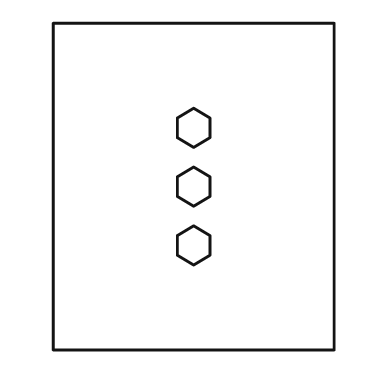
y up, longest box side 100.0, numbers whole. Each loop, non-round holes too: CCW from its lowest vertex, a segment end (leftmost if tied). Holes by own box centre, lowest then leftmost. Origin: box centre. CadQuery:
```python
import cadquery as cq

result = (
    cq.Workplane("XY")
    .moveTo(-43.0, -50.0)
    .lineTo(43.0, -50.0)
    .lineTo(43.0, 50.0)
    .lineTo(-43.0, 50.0)
    .close()
    .moveTo(0.0, -24.0)
    .lineTo(5.0, -21.0)
    .lineTo(5.0, -15.0)
    .lineTo(0.0, -12.0)
    .lineTo(-5.0, -15.0)
    .lineTo(-5.0, -21.0)
    .close()
    .moveTo(0.0, -6.0)
    .lineTo(5.0, -3.0)
    .lineTo(5.0, 3.0)
    .lineTo(0.0, 6.0)
    .lineTo(-5.0, 3.0)
    .lineTo(-5.0, -3.0)
    .close()
    .moveTo(0.0, 12.0)
    .lineTo(5.0, 15.0)
    .lineTo(5.0, 21.0)
    .lineTo(0.0, 24.0)
    .lineTo(-5.0, 21.0)
    .lineTo(-5.0, 15.0)
    .close()
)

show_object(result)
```